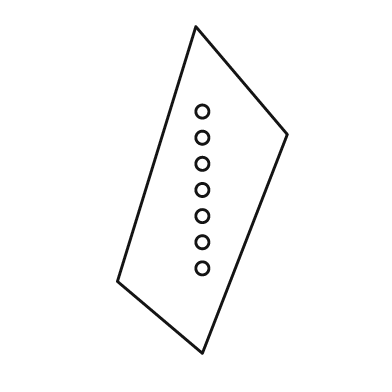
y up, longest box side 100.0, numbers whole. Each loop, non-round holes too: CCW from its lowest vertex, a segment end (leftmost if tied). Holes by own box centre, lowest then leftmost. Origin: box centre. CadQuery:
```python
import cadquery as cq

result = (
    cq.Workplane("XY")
    .moveTo(0.0, -50.0)
    .lineTo(26.0, 17.0)
    .lineTo(-2.0, 50.0)
    .lineTo(-26.0, -28.0)
    .close()
    .moveTo(0.0, -24.0)
    .circle(2.0)
    .moveTo(0.0, -16.0)
    .circle(2.0)
    .moveTo(0.0, -8.0)
    .circle(2.0)
    .moveTo(0.0, 0.0)
    .circle(2.0)
    .moveTo(0.0, 8.0)
    .circle(2.0)
    .moveTo(0.0, 16.0)
    .circle(2.0)
    .moveTo(0.0, 24.0)
    .circle(2.0)
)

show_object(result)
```